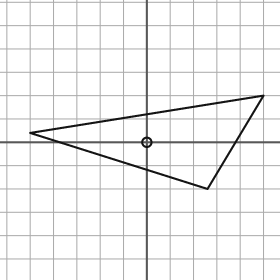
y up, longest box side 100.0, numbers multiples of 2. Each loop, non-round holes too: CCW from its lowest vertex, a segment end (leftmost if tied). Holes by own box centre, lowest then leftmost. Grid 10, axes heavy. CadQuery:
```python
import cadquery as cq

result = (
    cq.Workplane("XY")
    .moveTo(26.0, -20.0)
    .lineTo(50.0, 20.0)
    .lineTo(-50.0, 4.0)
    .close()
    .moveTo(0.0, 0.0)
    .circle(2.0)
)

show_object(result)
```